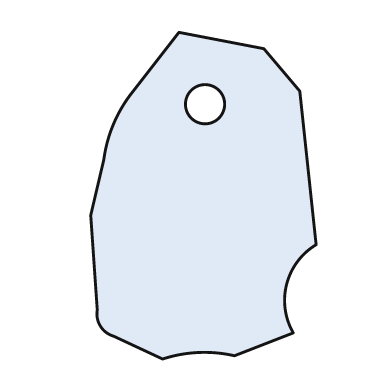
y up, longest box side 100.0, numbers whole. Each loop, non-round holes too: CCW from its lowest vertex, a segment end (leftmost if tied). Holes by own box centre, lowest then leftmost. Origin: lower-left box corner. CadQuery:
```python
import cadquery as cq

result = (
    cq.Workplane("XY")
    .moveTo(22.0, 0.0)
    .threePointArc((33.0, 2.0), (44.0, 1.0))
    .lineTo(62.0, 8.0)
    .threePointArc((60.0, 23.0), (69.0, 35.0))
    .lineTo(64.0, 82.0)
    .lineTo(53.0, 95.0)
    .lineTo(27.0, 100.0)
    .lineTo(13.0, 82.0)
    .threePointArc((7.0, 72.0), (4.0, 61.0))
    .lineTo(0.0, 44.0)
    .lineTo(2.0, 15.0)
    .threePointArc((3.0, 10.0), (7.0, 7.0))
    .close()
    .moveTo(35.0, 78.0)
    .circle(6.0)
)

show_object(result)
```